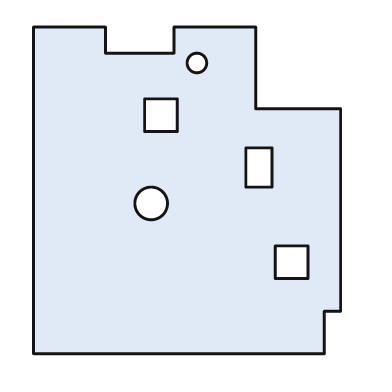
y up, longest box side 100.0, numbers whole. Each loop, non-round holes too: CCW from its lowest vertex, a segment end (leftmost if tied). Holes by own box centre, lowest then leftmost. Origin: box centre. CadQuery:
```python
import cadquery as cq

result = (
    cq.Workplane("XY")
    .moveTo(-47.0, -50.0)
    .lineTo(42.0, -50.0)
    .lineTo(42.0, -37.0)
    .lineTo(47.0, -37.0)
    .lineTo(47.0, 25.0)
    .lineTo(21.0, 25.0)
    .lineTo(21.0, 50.0)
    .lineTo(-4.0, 50.0)
    .lineTo(-4.0, 42.0)
    .lineTo(-25.0, 42.0)
    .lineTo(-25.0, 50.0)
    .lineTo(-47.0, 50.0)
    .close()
    .moveTo(27.0, -27.0)
    .lineTo(37.0, -27.0)
    .lineTo(37.0, -17.0)
    .lineTo(27.0, -17.0)
    .close()
    .moveTo(-11.0, -4.0)
    .circle(5.0)
    .moveTo(18.0, 1.0)
    .lineTo(26.0, 1.0)
    .lineTo(26.0, 13.0)
    .lineTo(18.0, 13.0)
    .close()
    .moveTo(-13.0, 18.0)
    .lineTo(-3.0, 18.0)
    .lineTo(-3.0, 28.0)
    .lineTo(-13.0, 28.0)
    .close()
    .moveTo(3.0, 39.0)
    .circle(3.0)
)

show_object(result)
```